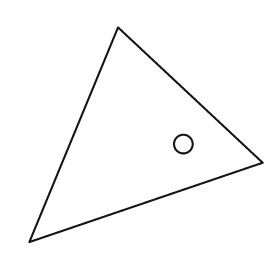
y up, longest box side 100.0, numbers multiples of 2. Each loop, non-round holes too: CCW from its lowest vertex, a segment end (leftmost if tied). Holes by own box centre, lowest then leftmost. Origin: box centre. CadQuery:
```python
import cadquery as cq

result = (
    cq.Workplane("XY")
    .moveTo(-50.0, -46.0)
    .lineTo(50.0, -12.0)
    .lineTo(-12.0, 46.0)
    .close()
    .moveTo(16.0, -4.0)
    .circle(4.0)
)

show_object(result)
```